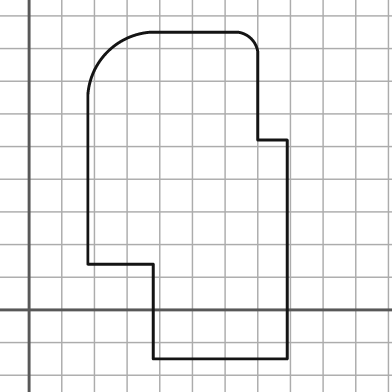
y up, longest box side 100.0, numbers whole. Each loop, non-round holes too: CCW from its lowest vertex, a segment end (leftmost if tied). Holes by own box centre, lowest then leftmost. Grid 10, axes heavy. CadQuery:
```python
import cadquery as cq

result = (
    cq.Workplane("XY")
    .moveTo(38.0, -15.0)
    .lineTo(79.0, -15.0)
    .lineTo(79.0, 52.0)
    .lineTo(70.0, 52.0)
    .lineTo(70.0, 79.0)
    .threePointArc((68.0, 83.0), (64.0, 85.0))
    .lineTo(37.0, 85.0)
    .threePointArc((24.0, 79.0), (18.0, 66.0))
    .lineTo(18.0, 14.0)
    .lineTo(38.0, 14.0)
    .close()
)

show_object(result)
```